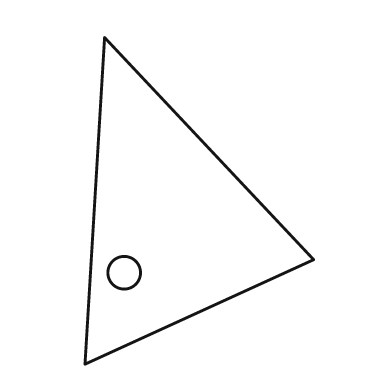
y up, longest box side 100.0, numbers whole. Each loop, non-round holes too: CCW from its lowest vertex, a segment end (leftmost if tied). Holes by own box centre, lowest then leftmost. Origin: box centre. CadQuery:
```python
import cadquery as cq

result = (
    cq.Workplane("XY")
    .moveTo(-35.0, -50.0)
    .lineTo(35.0, -18.0)
    .lineTo(-29.0, 50.0)
    .close()
    .moveTo(-23.0, -22.0)
    .circle(5.0)
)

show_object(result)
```